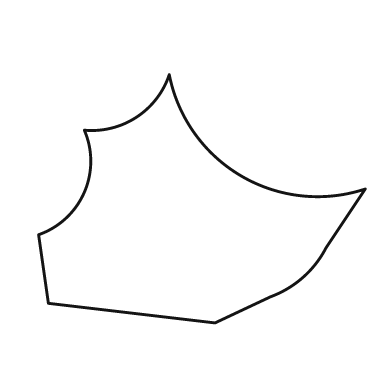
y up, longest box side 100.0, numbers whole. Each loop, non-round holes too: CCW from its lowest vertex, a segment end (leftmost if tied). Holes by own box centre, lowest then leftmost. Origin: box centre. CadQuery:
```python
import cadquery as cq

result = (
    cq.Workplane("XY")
    .moveTo(4.0, -38.0)
    .lineTo(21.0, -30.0)
    .threePointArc((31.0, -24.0), (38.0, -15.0))
    .lineTo(50.0, 3.0)
    .threePointArc((12.0, 7.0), (-10.0, 38.0))
    .threePointArc((-20.0, 25.0), (-36.0, 21.0))
    .threePointArc((-36.0, 2.0), (-50.0, -11.0))
    .lineTo(-47.0, -32.0)
    .close()
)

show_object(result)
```